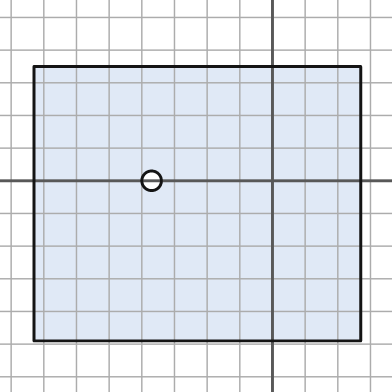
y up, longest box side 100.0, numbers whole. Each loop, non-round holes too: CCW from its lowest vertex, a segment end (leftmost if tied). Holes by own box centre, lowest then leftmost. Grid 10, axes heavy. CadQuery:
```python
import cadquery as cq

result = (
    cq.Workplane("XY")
    .moveTo(-73.0, -49.0)
    .lineTo(27.0, -49.0)
    .lineTo(27.0, 35.0)
    .lineTo(-73.0, 35.0)
    .close()
    .moveTo(-37.0, 0.0)
    .circle(3.0)
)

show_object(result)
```